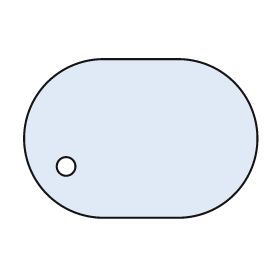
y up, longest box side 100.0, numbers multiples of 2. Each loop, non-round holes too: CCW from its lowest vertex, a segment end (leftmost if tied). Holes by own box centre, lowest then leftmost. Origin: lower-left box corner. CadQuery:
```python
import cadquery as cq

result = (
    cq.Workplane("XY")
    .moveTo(34.0, 0.0)
    .lineTo(66.0, 0.0)
    .threePointArc((100.0, 34.0), (66.0, 68.0))
    .lineTo(34.0, 68.0)
    .threePointArc((0.0, 34.0), (34.0, 0.0))
    .close()
    .moveTo(18.0, 22.0)
    .circle(4.0)
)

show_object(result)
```